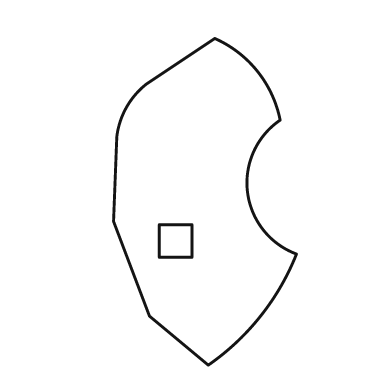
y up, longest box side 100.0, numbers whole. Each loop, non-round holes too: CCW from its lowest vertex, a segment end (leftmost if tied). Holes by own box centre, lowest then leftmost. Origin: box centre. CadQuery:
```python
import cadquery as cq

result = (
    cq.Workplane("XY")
    .moveTo(1.0, -50.0)
    .threePointArc((17.0, -35.0), (28.0, -16.0))
    .threePointArc((13.0, 3.0), (23.0, 25.0))
    .threePointArc((16.0, 40.0), (3.0, 50.0))
    .lineTo(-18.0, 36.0)
    .threePointArc((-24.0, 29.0), (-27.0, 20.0))
    .lineTo(-28.0, -6.0)
    .lineTo(-17.0, -35.0)
    .close()
    .moveTo(-14.0, -17.0)
    .lineTo(-4.0, -17.0)
    .lineTo(-4.0, -7.0)
    .lineTo(-14.0, -7.0)
    .close()
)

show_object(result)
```